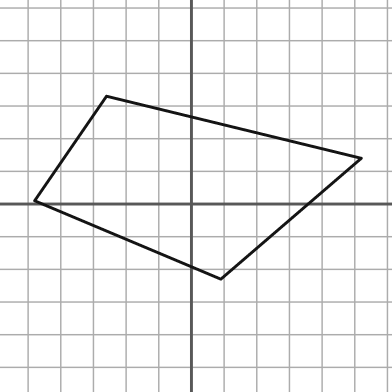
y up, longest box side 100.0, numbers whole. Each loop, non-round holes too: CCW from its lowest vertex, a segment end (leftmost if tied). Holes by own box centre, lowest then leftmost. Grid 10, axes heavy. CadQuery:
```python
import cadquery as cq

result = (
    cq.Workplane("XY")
    .moveTo(9.0, -23.0)
    .lineTo(52.0, 14.0)
    .lineTo(-26.0, 33.0)
    .lineTo(-48.0, 1.0)
    .close()
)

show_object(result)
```